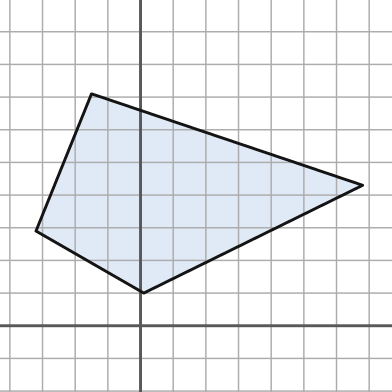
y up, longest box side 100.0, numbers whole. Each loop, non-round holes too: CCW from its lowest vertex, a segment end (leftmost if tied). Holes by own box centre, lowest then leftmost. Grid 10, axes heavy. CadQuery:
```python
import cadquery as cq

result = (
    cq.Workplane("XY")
    .moveTo(1.0, 10.0)
    .lineTo(68.0, 43.0)
    .lineTo(-15.0, 71.0)
    .lineTo(-32.0, 29.0)
    .close()
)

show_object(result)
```